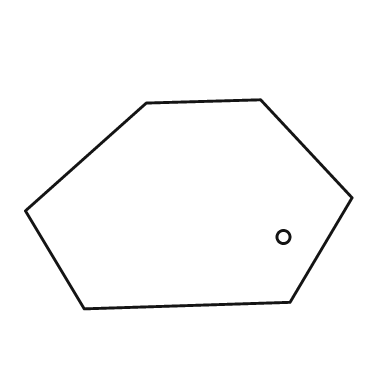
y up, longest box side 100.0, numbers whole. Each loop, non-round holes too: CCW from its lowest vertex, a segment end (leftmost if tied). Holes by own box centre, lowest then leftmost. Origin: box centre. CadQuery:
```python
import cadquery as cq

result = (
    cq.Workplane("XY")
    .moveTo(-32.0, -32.0)
    .lineTo(31.0, -30.0)
    .lineTo(50.0, 2.0)
    .lineTo(22.0, 32.0)
    .lineTo(-13.0, 31.0)
    .lineTo(-50.0, -2.0)
    .close()
    .moveTo(29.0, -10.0)
    .circle(2.0)
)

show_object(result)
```